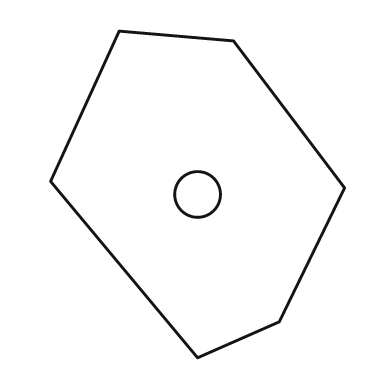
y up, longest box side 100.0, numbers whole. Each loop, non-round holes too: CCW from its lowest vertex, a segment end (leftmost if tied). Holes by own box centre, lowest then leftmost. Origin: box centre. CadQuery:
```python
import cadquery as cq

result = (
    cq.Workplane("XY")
    .moveTo(0.0, -50.0)
    .lineTo(25.0, -39.0)
    .lineTo(45.0, 2.0)
    .lineTo(11.0, 47.0)
    .lineTo(-24.0, 50.0)
    .lineTo(-45.0, 4.0)
    .close()
    .moveTo(0.0, 0.0)
    .circle(7.0)
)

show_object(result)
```